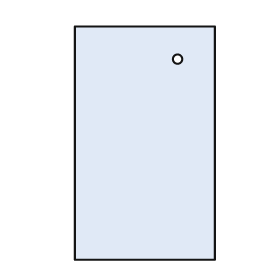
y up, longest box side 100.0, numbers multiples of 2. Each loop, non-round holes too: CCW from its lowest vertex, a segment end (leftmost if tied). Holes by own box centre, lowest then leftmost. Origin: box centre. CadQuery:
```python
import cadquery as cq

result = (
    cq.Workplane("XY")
    .moveTo(-30.0, -50.0)
    .lineTo(30.0, -50.0)
    .lineTo(30.0, 50.0)
    .lineTo(-30.0, 50.0)
    .close()
    .moveTo(14.0, 36.0)
    .circle(2.0)
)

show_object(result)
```